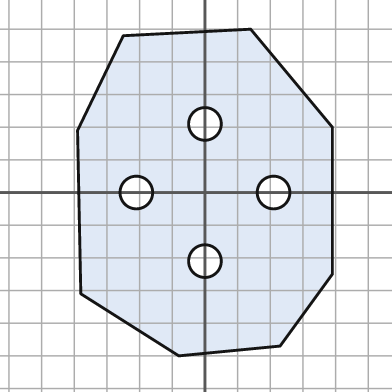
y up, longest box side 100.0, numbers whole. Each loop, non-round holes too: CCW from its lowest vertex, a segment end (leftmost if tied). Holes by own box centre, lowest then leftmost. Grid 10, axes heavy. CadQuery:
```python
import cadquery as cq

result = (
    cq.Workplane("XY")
    .moveTo(-8.0, -50.0)
    .lineTo(23.0, -47.0)
    .lineTo(39.0, -25.0)
    .lineTo(39.0, 20.0)
    .lineTo(14.0, 50.0)
    .lineTo(-25.0, 48.0)
    .lineTo(-39.0, 19.0)
    .lineTo(-38.0, -31.0)
    .close()
    .moveTo(0.0, -21.0)
    .circle(5.0)
    .moveTo(-21.0, 0.0)
    .circle(5.0)
    .moveTo(21.0, 0.0)
    .circle(5.0)
    .moveTo(0.0, 21.0)
    .circle(5.0)
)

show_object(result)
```